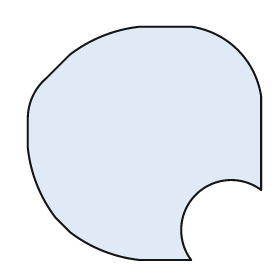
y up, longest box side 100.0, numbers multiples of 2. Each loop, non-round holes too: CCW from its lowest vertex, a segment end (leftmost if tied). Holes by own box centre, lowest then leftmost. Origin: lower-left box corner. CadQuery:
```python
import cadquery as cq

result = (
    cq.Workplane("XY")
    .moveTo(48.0, 0.0)
    .lineTo(70.0, 0.0)
    .threePointArc((72.0, 28.0), (100.0, 30.0))
    .lineTo(100.0, 70.0)
    .threePointArc((90.0, 90.0), (70.0, 100.0))
    .lineTo(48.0, 100.0)
    .threePointArc((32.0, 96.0), (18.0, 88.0))
    .lineTo(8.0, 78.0)
    .threePointArc((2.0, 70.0), (0.0, 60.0))
    .lineTo(0.0, 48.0)
    .threePointArc((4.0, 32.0), (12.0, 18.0))
    .lineTo(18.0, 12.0)
    .threePointArc((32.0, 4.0), (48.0, 0.0))
    .close()
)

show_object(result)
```